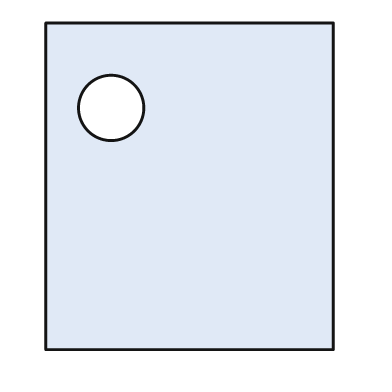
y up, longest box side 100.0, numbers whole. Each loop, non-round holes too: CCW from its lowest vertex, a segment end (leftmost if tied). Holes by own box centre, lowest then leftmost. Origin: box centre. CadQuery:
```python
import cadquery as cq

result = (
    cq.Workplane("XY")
    .moveTo(-44.0, -50.0)
    .lineTo(44.0, -50.0)
    .lineTo(44.0, 50.0)
    .lineTo(-44.0, 50.0)
    .close()
    .moveTo(-24.0, 24.0)
    .circle(10.0)
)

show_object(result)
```